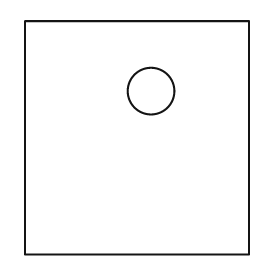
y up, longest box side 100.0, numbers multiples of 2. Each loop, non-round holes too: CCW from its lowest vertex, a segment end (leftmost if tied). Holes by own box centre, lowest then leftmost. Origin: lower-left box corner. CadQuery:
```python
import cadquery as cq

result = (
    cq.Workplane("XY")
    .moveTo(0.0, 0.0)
    .lineTo(96.0, 0.0)
    .lineTo(96.0, 100.0)
    .lineTo(0.0, 100.0)
    .close()
    .moveTo(54.0, 70.0)
    .circle(10.0)
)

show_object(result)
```